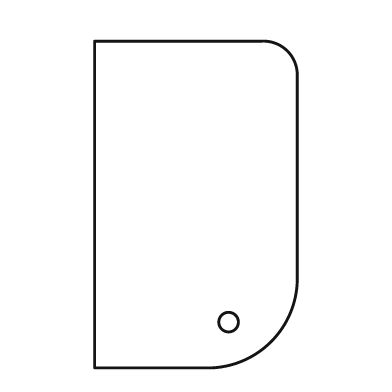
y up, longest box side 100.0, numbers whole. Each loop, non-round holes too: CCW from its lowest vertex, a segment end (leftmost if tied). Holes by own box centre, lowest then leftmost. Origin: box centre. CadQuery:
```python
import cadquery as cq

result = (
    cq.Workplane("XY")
    .moveTo(-31.0, -50.0)
    .lineTo(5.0, -50.0)
    .threePointArc((23.0, -42.0), (31.0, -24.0))
    .lineTo(31.0, 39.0)
    .threePointArc((28.0, 47.0), (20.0, 50.0))
    .lineTo(-31.0, 50.0)
    .close()
    .moveTo(10.0, -36.0)
    .circle(3.0)
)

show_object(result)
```